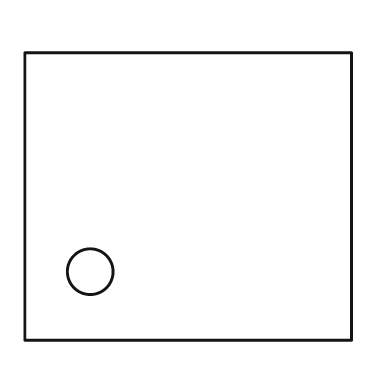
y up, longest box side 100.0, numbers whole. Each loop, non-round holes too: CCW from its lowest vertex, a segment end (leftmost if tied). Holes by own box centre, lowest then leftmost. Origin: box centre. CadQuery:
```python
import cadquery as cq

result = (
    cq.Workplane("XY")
    .moveTo(-50.0, -44.0)
    .lineTo(50.0, -44.0)
    .lineTo(50.0, 44.0)
    .lineTo(-50.0, 44.0)
    .close()
    .moveTo(-30.0, -23.0)
    .circle(7.0)
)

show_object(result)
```